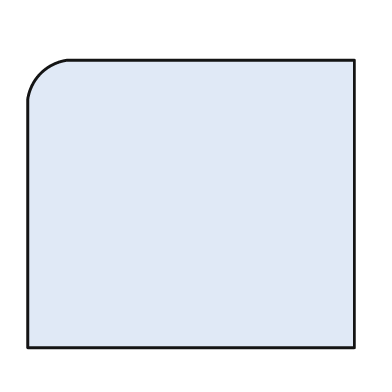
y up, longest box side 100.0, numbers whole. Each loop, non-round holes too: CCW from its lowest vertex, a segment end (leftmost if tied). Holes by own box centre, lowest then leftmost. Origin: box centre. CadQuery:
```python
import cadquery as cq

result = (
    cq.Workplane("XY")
    .moveTo(-50.0, -44.0)
    .lineTo(50.0, -44.0)
    .lineTo(50.0, 44.0)
    .lineTo(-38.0, 44.0)
    .threePointArc((-46.0, 40.0), (-50.0, 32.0))
    .close()
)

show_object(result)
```